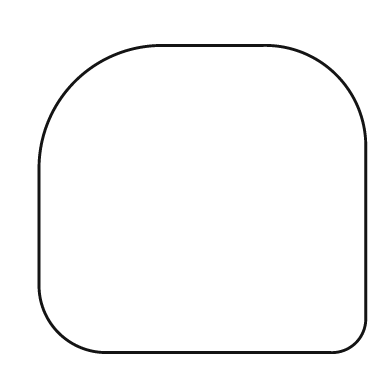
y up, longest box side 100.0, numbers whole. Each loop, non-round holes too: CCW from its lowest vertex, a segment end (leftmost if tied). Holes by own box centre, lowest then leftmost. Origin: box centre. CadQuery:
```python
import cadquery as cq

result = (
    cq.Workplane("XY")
    .moveTo(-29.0, -47.0)
    .lineTo(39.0, -47.0)
    .threePointArc((47.0, -44.0), (50.0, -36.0))
    .lineTo(50.0, 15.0)
    .threePointArc((41.0, 38.0), (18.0, 47.0))
    .lineTo(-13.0, 47.0)
    .threePointArc((-39.0, 36.0), (-50.0, 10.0))
    .lineTo(-50.0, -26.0)
    .threePointArc((-44.0, -41.0), (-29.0, -47.0))
    .close()
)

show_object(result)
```